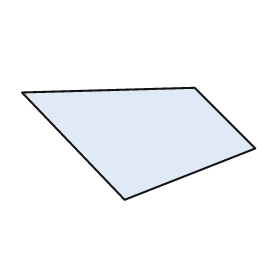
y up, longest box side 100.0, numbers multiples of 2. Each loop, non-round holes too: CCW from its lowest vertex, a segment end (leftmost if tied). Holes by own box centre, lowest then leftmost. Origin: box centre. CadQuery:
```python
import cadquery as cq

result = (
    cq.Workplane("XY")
    .moveTo(-6.0, -24.0)
    .lineTo(50.0, -2.0)
    .lineTo(24.0, 24.0)
    .lineTo(-50.0, 22.0)
    .close()
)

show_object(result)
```